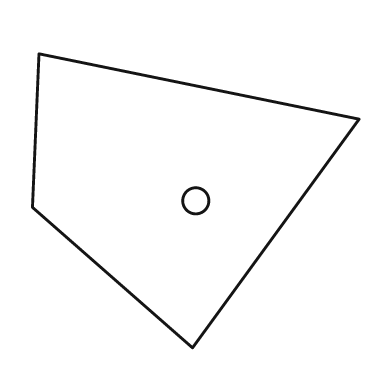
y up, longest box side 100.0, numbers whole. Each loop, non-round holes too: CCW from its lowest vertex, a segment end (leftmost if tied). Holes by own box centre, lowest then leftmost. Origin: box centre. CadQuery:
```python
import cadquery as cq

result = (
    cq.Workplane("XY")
    .moveTo(-1.0, -45.0)
    .lineTo(50.0, 25.0)
    .lineTo(-48.0, 45.0)
    .lineTo(-50.0, -2.0)
    .close()
    .moveTo(0.0, 0.0)
    .circle(4.0)
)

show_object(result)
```